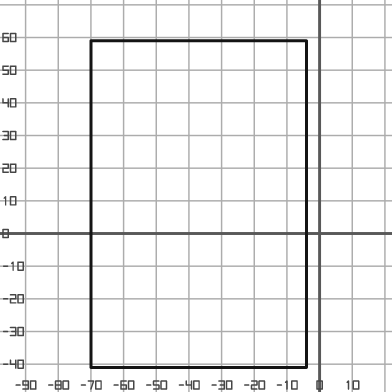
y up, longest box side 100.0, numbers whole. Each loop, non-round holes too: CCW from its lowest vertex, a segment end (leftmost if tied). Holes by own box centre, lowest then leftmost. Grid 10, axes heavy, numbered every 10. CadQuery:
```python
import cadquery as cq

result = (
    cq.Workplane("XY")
    .moveTo(-70.0, -41.0)
    .lineTo(-4.0, -41.0)
    .lineTo(-4.0, 59.0)
    .lineTo(-70.0, 59.0)
    .close()
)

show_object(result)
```